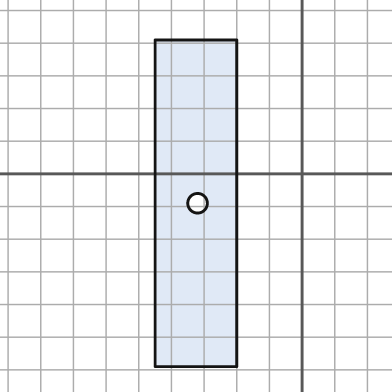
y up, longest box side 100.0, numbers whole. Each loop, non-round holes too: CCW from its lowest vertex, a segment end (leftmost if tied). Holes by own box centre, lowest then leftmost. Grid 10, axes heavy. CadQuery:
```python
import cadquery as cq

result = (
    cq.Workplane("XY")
    .moveTo(-45.0, -59.0)
    .lineTo(-20.0, -59.0)
    .lineTo(-20.0, 41.0)
    .lineTo(-45.0, 41.0)
    .close()
    .moveTo(-32.0, -9.0)
    .circle(3.0)
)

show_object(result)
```